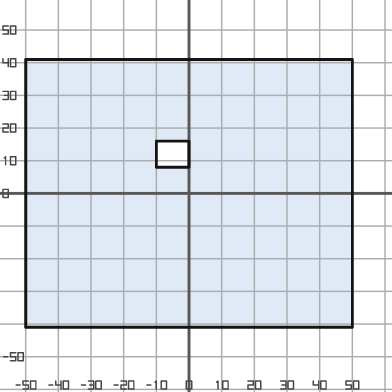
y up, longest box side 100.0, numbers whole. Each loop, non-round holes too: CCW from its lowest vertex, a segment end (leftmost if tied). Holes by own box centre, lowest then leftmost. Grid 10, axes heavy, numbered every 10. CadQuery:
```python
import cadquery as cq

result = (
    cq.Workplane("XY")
    .moveTo(-50.0, -41.0)
    .lineTo(50.0, -41.0)
    .lineTo(50.0, 41.0)
    .lineTo(-50.0, 41.0)
    .close()
    .moveTo(-10.0, 8.0)
    .lineTo(0.0, 8.0)
    .lineTo(0.0, 16.0)
    .lineTo(-10.0, 16.0)
    .close()
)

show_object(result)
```